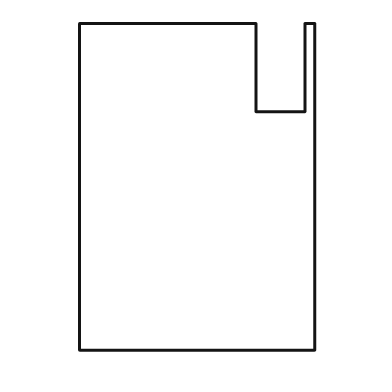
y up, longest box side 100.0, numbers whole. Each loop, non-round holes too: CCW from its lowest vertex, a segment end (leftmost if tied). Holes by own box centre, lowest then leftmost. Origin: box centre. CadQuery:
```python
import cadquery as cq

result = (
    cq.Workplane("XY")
    .moveTo(-36.0, -50.0)
    .lineTo(36.0, -50.0)
    .lineTo(36.0, 50.0)
    .lineTo(33.0, 50.0)
    .lineTo(33.0, 23.0)
    .lineTo(18.0, 23.0)
    .lineTo(18.0, 50.0)
    .lineTo(-36.0, 50.0)
    .close()
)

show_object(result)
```